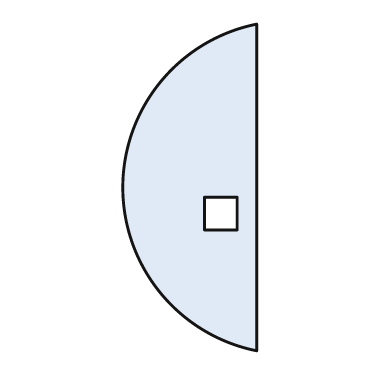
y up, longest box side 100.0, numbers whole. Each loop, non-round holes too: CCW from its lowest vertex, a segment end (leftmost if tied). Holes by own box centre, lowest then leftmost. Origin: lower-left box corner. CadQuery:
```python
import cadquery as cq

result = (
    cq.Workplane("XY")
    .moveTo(41.0, 0.0)
    .lineTo(41.0, 100.0)
    .threePointArc((0.0, 50.0), (41.0, 0.0))
    .close()
    .moveTo(25.0, 37.0)
    .lineTo(35.0, 37.0)
    .lineTo(35.0, 47.0)
    .lineTo(25.0, 47.0)
    .close()
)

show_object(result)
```